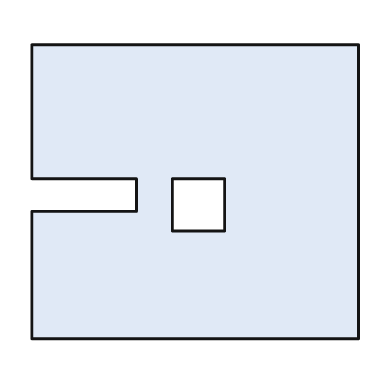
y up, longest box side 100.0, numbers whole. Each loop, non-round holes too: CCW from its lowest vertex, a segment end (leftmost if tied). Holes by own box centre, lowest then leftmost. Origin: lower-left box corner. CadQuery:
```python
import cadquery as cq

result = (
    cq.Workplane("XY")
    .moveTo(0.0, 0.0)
    .lineTo(100.0, 0.0)
    .lineTo(100.0, 90.0)
    .lineTo(0.0, 90.0)
    .lineTo(0.0, 49.0)
    .lineTo(32.0, 49.0)
    .lineTo(32.0, 39.0)
    .lineTo(0.0, 39.0)
    .close()
    .moveTo(43.0, 33.0)
    .lineTo(59.0, 33.0)
    .lineTo(59.0, 49.0)
    .lineTo(43.0, 49.0)
    .close()
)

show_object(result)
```